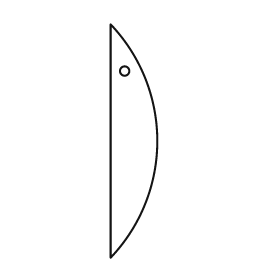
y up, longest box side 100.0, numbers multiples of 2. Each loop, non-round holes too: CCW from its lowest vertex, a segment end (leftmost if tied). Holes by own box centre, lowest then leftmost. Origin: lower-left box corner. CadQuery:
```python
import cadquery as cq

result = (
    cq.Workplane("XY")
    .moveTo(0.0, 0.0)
    .threePointArc((20.0, 50.0), (0.0, 100.0))
    .close()
    .moveTo(6.0, 80.0)
    .circle(2.0)
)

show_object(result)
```